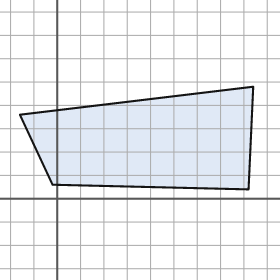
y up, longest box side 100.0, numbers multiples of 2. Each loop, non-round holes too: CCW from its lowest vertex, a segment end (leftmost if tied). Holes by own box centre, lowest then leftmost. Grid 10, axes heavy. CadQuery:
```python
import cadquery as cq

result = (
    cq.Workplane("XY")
    .moveTo(82.0, 4.0)
    .lineTo(84.0, 48.0)
    .lineTo(-16.0, 36.0)
    .lineTo(-2.0, 6.0)
    .close()
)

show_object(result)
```